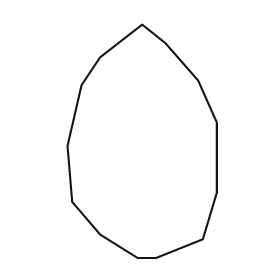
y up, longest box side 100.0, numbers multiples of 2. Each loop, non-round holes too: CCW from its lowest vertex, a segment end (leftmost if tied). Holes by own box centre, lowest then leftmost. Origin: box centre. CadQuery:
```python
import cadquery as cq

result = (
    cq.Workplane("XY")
    .moveTo(-2.0, -50.0)
    .lineTo(6.0, -50.0)
    .lineTo(26.0, -42.0)
    .lineTo(32.0, -22.0)
    .lineTo(32.0, 8.0)
    .lineTo(24.0, 26.0)
    .lineTo(10.0, 42.0)
    .lineTo(0.0, 50.0)
    .lineTo(-18.0, 36.0)
    .lineTo(-26.0, 24.0)
    .lineTo(-32.0, -2.0)
    .lineTo(-30.0, -26.0)
    .lineTo(-18.0, -40.0)
    .close()
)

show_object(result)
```